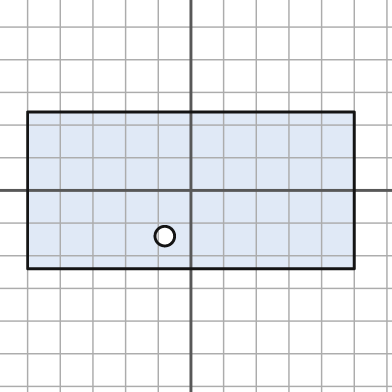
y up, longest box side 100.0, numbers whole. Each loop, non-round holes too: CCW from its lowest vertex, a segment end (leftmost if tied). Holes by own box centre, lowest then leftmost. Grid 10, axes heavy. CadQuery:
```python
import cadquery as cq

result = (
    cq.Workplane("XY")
    .moveTo(-50.0, -24.0)
    .lineTo(50.0, -24.0)
    .lineTo(50.0, 24.0)
    .lineTo(-50.0, 24.0)
    .close()
    .moveTo(-8.0, -14.0)
    .circle(3.0)
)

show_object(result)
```